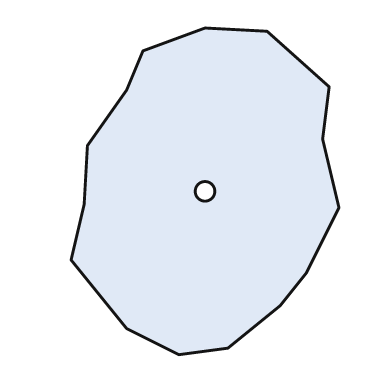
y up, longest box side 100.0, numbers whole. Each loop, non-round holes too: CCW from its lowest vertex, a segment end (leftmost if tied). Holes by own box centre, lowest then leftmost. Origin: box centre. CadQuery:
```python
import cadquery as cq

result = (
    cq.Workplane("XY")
    .moveTo(-8.0, -50.0)
    .lineTo(7.0, -48.0)
    .lineTo(23.0, -35.0)
    .lineTo(31.0, -25.0)
    .lineTo(41.0, -5.0)
    .lineTo(36.0, 16.0)
    .lineTo(38.0, 32.0)
    .lineTo(19.0, 49.0)
    .lineTo(0.0, 50.0)
    .lineTo(-19.0, 43.0)
    .lineTo(-24.0, 31.0)
    .lineTo(-36.0, 14.0)
    .lineTo(-37.0, -4.0)
    .lineTo(-41.0, -21.0)
    .lineTo(-24.0, -42.0)
    .close()
    .moveTo(0.0, 0.0)
    .circle(3.0)
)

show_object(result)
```